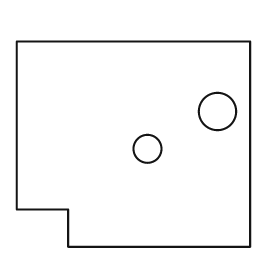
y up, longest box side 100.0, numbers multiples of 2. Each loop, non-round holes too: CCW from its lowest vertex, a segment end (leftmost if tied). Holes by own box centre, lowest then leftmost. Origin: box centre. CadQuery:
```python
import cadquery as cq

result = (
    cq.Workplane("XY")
    .moveTo(-28.0, -44.0)
    .lineTo(50.0, -44.0)
    .lineTo(50.0, 44.0)
    .lineTo(-50.0, 44.0)
    .lineTo(-50.0, -28.0)
    .lineTo(-28.0, -28.0)
    .close()
    .moveTo(6.0, -2.0)
    .circle(6.0)
    .moveTo(36.0, 14.0)
    .circle(8.0)
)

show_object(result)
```